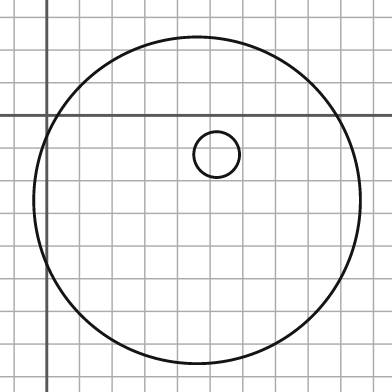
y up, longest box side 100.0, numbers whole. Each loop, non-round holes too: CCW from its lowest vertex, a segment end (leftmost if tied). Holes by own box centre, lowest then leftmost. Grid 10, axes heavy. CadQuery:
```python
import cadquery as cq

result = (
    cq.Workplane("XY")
    .moveTo(46.0, -26.0)
    .circle(50.0)
    .moveTo(52.0, -12.0)
    .circle(7.0)
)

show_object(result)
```